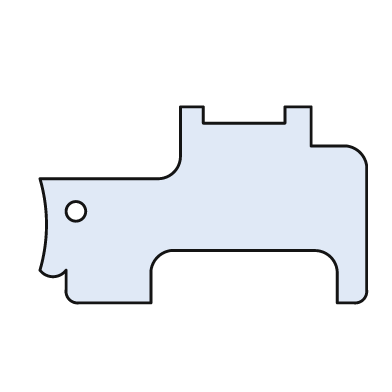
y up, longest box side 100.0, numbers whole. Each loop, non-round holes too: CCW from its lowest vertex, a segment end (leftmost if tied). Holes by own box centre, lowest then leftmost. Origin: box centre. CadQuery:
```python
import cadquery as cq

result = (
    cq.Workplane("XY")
    .moveTo(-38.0, -30.0)
    .lineTo(-16.0, -30.0)
    .lineTo(-16.0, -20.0)
    .threePointArc((-14.0, -16.0), (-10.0, -14.0))
    .lineTo(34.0, -14.0)
    .threePointArc((39.0, -16.0), (41.0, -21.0))
    .lineTo(41.0, -30.0)
    .lineTo(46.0, -30.0)
    .threePointArc((49.0, -29.0), (50.0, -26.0))
    .lineTo(50.0, 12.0)
    .threePointArc((48.0, 16.0), (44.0, 18.0))
    .lineTo(33.0, 18.0)
    .lineTo(33.0, 30.0)
    .lineTo(25.0, 30.0)
    .lineTo(25.0, 25.0)
    .lineTo(0.0, 25.0)
    .lineTo(0.0, 30.0)
    .lineTo(-7.0, 30.0)
    .lineTo(-7.0, 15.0)
    .threePointArc((-9.0, 10.0), (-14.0, 8.0))
    .lineTo(-50.0, 8.0)
    .threePointArc((-48.0, -6.0), (-50.0, -20.0))
    .threePointArc((-46.0, -22.0), (-42.0, -20.0))
    .lineTo(-42.0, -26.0)
    .threePointArc((-41.0, -29.0), (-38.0, -30.0))
    .close()
    .moveTo(-39.0, -2.0)
    .circle(3.0)
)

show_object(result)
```